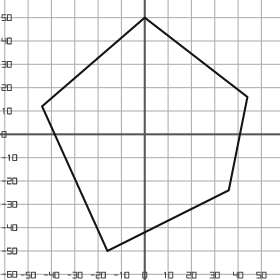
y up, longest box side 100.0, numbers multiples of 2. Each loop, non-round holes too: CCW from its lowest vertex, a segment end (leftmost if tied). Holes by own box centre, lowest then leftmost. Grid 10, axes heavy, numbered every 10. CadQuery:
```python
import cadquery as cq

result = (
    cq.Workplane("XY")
    .moveTo(-16.0, -50.0)
    .lineTo(36.0, -24.0)
    .lineTo(44.0, 16.0)
    .lineTo(0.0, 50.0)
    .lineTo(-44.0, 12.0)
    .close()
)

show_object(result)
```